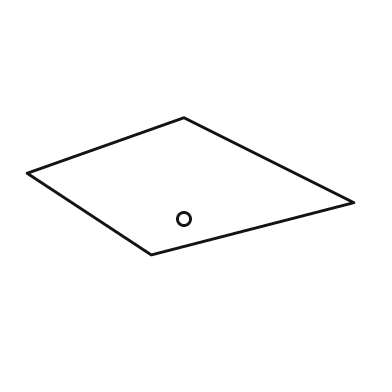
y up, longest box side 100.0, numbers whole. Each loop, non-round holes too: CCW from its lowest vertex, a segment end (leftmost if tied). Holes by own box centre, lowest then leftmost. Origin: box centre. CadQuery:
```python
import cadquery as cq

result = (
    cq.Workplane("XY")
    .moveTo(-12.0, -21.0)
    .lineTo(50.0, -5.0)
    .lineTo(-2.0, 21.0)
    .lineTo(-50.0, 4.0)
    .close()
    .moveTo(-2.0, -10.0)
    .circle(2.0)
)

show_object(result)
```